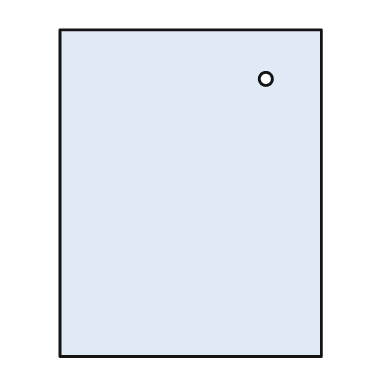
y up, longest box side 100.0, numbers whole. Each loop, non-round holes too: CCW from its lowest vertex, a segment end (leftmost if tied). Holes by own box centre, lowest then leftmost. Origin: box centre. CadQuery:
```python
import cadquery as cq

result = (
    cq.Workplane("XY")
    .moveTo(-40.0, -50.0)
    .lineTo(40.0, -50.0)
    .lineTo(40.0, 50.0)
    .lineTo(-40.0, 50.0)
    .close()
    .moveTo(23.0, 35.0)
    .circle(2.0)
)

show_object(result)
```